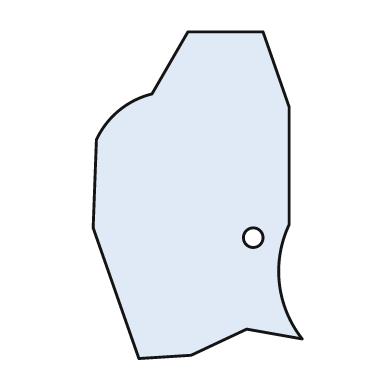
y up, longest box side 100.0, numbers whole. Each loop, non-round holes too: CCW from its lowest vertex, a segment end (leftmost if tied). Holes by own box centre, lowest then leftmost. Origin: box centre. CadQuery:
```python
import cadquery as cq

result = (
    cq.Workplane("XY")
    .moveTo(-18.0, -50.0)
    .lineTo(-2.0, -49.0)
    .lineTo(15.0, -41.0)
    .lineTo(32.0, -44.0)
    .threePointArc((25.0, -27.0), (28.0, -9.0))
    .lineTo(28.0, 27.0)
    .lineTo(20.0, 50.0)
    .lineTo(-3.0, 50.0)
    .lineTo(-14.0, 31.0)
    .threePointArc((-24.0, 26.0), (-31.0, 17.0))
    .lineTo(-32.0, -10.0)
    .close()
    .moveTo(17.0, -13.0)
    .circle(3.0)
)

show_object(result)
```